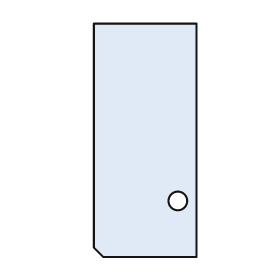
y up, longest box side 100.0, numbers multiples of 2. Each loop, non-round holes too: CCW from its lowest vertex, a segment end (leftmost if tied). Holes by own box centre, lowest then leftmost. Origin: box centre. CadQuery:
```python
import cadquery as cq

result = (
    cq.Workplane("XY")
    .moveTo(-18.0, -50.0)
    .lineTo(22.0, -50.0)
    .lineTo(22.0, 50.0)
    .lineTo(-22.0, 50.0)
    .lineTo(-22.0, -46.0)
    .close()
    .moveTo(14.0, -26.0)
    .circle(4.0)
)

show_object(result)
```